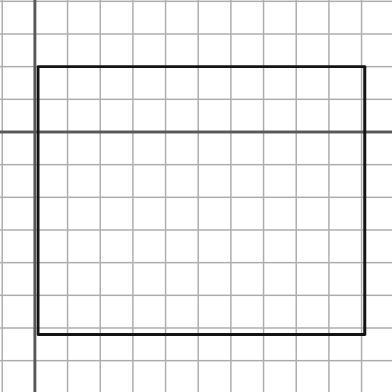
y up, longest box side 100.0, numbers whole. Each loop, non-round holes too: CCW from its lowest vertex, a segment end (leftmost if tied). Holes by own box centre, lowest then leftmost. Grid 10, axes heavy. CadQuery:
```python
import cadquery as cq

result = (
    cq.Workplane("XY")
    .moveTo(1.0, -62.0)
    .lineTo(101.0, -62.0)
    .lineTo(101.0, 20.0)
    .lineTo(1.0, 20.0)
    .close()
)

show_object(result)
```